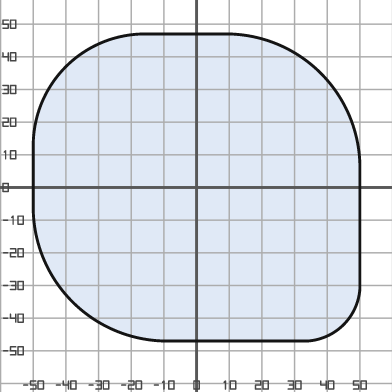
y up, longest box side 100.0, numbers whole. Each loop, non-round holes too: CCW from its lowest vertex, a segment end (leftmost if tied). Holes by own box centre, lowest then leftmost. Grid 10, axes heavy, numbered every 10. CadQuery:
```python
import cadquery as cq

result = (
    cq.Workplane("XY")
    .moveTo(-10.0, -47.0)
    .lineTo(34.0, -47.0)
    .threePointArc((45.0, -42.0), (50.0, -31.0))
    .lineTo(50.0, 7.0)
    .threePointArc((38.0, 35.0), (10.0, 47.0))
    .lineTo(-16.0, 47.0)
    .threePointArc((-40.0, 37.0), (-50.0, 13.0))
    .lineTo(-50.0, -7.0)
    .threePointArc((-38.0, -35.0), (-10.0, -47.0))
    .close()
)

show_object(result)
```